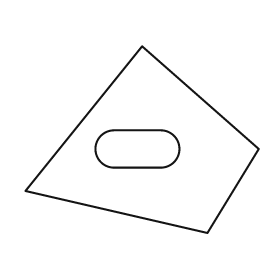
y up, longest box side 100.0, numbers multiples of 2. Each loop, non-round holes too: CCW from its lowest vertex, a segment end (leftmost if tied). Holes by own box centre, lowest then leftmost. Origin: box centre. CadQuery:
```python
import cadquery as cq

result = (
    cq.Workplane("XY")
    .moveTo(28.0, -40.0)
    .lineTo(50.0, -4.0)
    .lineTo(0.0, 40.0)
    .lineTo(-50.0, -22.0)
    .close()
    .moveTo(-12.0, -12.0)
    .lineTo(8.0, -12.0)
    .threePointArc((16.0, -4.0), (8.0, 4.0))
    .lineTo(-12.0, 4.0)
    .threePointArc((-20.0, -4.0), (-12.0, -12.0))
    .close()
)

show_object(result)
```